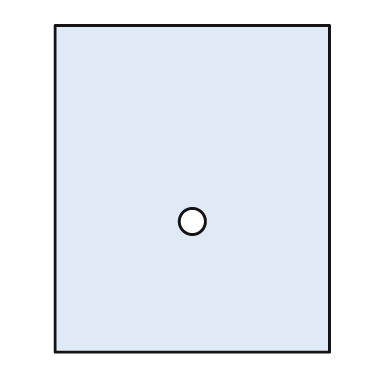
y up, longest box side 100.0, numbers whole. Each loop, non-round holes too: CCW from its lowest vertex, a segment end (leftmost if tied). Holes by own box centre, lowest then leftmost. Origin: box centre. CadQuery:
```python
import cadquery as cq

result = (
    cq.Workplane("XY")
    .moveTo(-42.0, -50.0)
    .lineTo(42.0, -50.0)
    .lineTo(42.0, 50.0)
    .lineTo(-42.0, 50.0)
    .close()
    .moveTo(0.0, -10.0)
    .circle(4.0)
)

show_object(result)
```